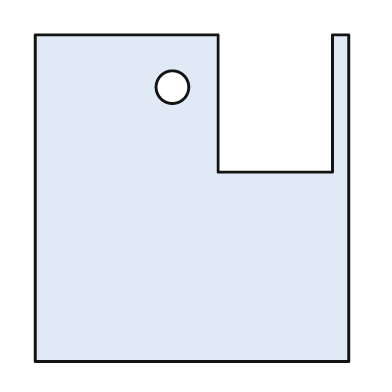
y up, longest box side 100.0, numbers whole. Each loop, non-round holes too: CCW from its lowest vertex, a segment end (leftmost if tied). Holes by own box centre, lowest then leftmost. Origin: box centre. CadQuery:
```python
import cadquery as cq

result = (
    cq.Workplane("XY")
    .moveTo(-48.0, -50.0)
    .lineTo(48.0, -50.0)
    .lineTo(48.0, 50.0)
    .lineTo(43.0, 50.0)
    .lineTo(43.0, 8.0)
    .lineTo(8.0, 8.0)
    .lineTo(8.0, 50.0)
    .lineTo(-48.0, 50.0)
    .close()
    .moveTo(-6.0, 34.0)
    .circle(5.0)
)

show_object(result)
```